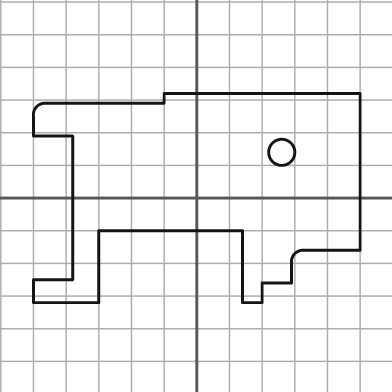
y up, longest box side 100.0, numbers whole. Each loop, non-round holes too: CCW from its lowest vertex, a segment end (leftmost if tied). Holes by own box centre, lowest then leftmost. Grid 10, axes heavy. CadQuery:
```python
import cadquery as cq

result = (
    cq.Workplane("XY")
    .moveTo(-50.0, -32.0)
    .lineTo(-30.0, -32.0)
    .lineTo(-30.0, -10.0)
    .lineTo(14.0, -10.0)
    .lineTo(14.0, -32.0)
    .lineTo(20.0, -32.0)
    .lineTo(20.0, -26.0)
    .lineTo(29.0, -26.0)
    .lineTo(29.0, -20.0)
    .threePointArc((30.0, -17.0), (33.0, -16.0))
    .lineTo(50.0, -16.0)
    .lineTo(50.0, 32.0)
    .lineTo(-10.0, 32.0)
    .lineTo(-10.0, 29.0)
    .lineTo(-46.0, 29.0)
    .threePointArc((-49.0, 28.0), (-50.0, 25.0))
    .lineTo(-50.0, 19.0)
    .lineTo(-38.0, 19.0)
    .lineTo(-38.0, -25.0)
    .lineTo(-50.0, -25.0)
    .close()
    .moveTo(26.0, 14.0)
    .circle(4.0)
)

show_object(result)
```